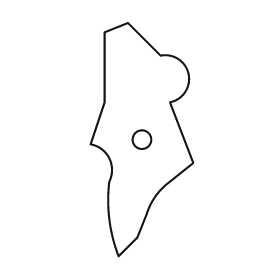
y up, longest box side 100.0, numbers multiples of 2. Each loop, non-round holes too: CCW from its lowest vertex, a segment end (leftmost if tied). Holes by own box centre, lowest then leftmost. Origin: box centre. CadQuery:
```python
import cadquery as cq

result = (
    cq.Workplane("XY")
    .moveTo(-10.0, -50.0)
    .lineTo(-2.0, -42.0)
    .lineTo(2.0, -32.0)
    .threePointArc((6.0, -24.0), (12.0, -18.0))
    .lineTo(22.0, -10.0)
    .lineTo(12.0, 16.0)
    .threePointArc((20.0, 28.0), (8.0, 36.0))
    .lineTo(-6.0, 50.0)
    .lineTo(-16.0, 46.0)
    .lineTo(-16.0, 16.0)
    .lineTo(-22.0, -2.0)
    .threePointArc((-14.0, -8.0), (-14.0, -18.0))
    .threePointArc((-14.0, -34.0), (-10.0, -50.0))
    .close()
    .moveTo(0.0, 0.0)
    .circle(4.0)
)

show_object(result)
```